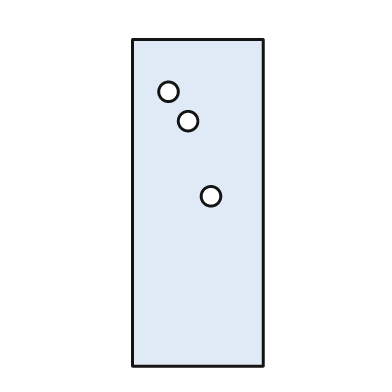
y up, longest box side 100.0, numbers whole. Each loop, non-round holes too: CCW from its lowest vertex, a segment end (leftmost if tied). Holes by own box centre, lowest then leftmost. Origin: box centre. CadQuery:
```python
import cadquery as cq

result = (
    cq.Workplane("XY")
    .moveTo(-20.0, -50.0)
    .lineTo(20.0, -50.0)
    .lineTo(20.0, 50.0)
    .lineTo(-20.0, 50.0)
    .close()
    .moveTo(4.0, 2.0)
    .circle(3.0)
    .moveTo(-3.0, 25.0)
    .circle(3.0)
    .moveTo(-9.0, 34.0)
    .circle(3.0)
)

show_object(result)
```